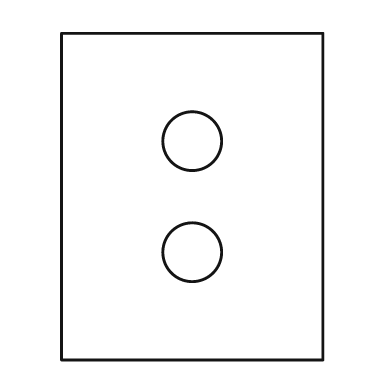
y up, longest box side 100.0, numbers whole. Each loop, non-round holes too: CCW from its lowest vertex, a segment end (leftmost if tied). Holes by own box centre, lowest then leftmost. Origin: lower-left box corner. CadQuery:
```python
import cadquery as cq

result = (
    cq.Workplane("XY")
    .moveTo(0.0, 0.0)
    .lineTo(80.0, 0.0)
    .lineTo(80.0, 100.0)
    .lineTo(0.0, 100.0)
    .close()
    .moveTo(40.0, 33.0)
    .circle(9.0)
    .moveTo(40.0, 67.0)
    .circle(9.0)
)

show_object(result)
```